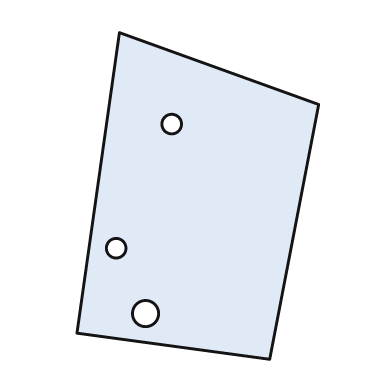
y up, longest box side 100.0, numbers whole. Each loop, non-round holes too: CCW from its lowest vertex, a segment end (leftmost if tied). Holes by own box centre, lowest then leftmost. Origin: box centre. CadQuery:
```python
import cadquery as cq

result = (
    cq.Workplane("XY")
    .moveTo(22.0, -50.0)
    .lineTo(37.0, 28.0)
    .lineTo(-24.0, 50.0)
    .lineTo(-37.0, -42.0)
    .close()
    .moveTo(-16.0, -36.0)
    .circle(4.0)
    .moveTo(-25.0, -16.0)
    .circle(3.0)
    .moveTo(-8.0, 22.0)
    .circle(3.0)
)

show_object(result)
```